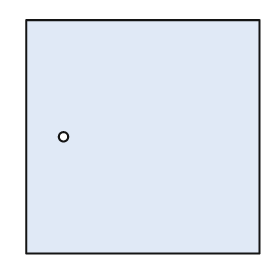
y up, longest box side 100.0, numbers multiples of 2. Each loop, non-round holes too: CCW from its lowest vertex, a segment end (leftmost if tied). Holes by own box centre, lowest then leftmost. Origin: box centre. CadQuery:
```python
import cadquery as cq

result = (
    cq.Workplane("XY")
    .moveTo(-50.0, -50.0)
    .lineTo(50.0, -50.0)
    .lineTo(50.0, 50.0)
    .lineTo(-50.0, 50.0)
    .close()
    .moveTo(-34.0, 0.0)
    .circle(2.0)
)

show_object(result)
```